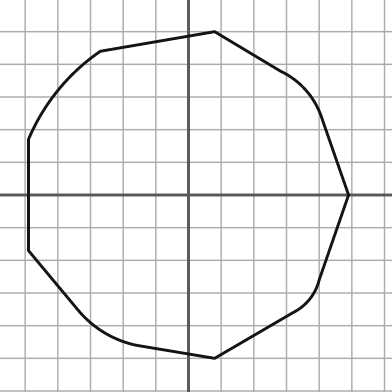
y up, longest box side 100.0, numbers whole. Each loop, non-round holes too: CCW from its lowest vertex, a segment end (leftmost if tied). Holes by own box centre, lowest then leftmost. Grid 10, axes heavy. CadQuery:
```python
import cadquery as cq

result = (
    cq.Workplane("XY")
    .moveTo(8.0, -50.0)
    .lineTo(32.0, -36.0)
    .threePointArc((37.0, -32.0), (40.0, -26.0))
    .lineTo(49.0, 0.0)
    .lineTo(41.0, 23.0)
    .threePointArc((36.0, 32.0), (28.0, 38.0))
    .lineTo(8.0, 50.0)
    .lineTo(-27.0, 44.0)
    .threePointArc((-40.0, 32.0), (-49.0, 17.0))
    .lineTo(-49.0, -17.0)
    .lineTo(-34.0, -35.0)
    .threePointArc((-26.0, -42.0), (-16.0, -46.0))
    .close()
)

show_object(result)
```